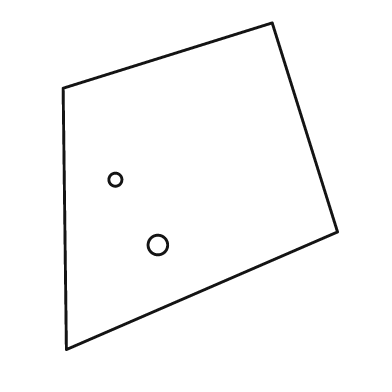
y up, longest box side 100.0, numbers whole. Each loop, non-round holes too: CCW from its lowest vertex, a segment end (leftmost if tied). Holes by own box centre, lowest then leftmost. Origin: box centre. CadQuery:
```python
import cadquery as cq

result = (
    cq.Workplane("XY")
    .moveTo(-41.0, -50.0)
    .lineTo(42.0, -14.0)
    .lineTo(22.0, 50.0)
    .lineTo(-42.0, 30.0)
    .close()
    .moveTo(-13.0, -18.0)
    .circle(3.0)
    .moveTo(-26.0, 2.0)
    .circle(2.0)
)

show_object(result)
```